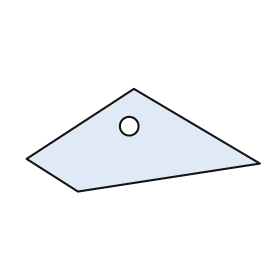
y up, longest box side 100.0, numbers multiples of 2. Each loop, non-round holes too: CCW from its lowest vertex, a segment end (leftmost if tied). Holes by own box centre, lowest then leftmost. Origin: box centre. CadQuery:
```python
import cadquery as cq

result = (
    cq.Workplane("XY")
    .moveTo(-28.0, -22.0)
    .lineTo(50.0, -10.0)
    .lineTo(-4.0, 22.0)
    .lineTo(-50.0, -8.0)
    .close()
    .moveTo(-6.0, 6.0)
    .circle(4.0)
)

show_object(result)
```